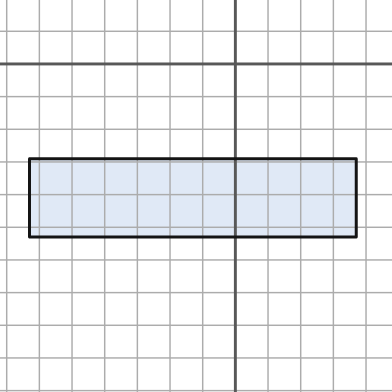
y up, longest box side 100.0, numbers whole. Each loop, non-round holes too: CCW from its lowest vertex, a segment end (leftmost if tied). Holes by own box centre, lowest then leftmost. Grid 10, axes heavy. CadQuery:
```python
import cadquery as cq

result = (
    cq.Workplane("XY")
    .moveTo(-63.0, -53.0)
    .lineTo(37.0, -53.0)
    .lineTo(37.0, -29.0)
    .lineTo(-63.0, -29.0)
    .close()
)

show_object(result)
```